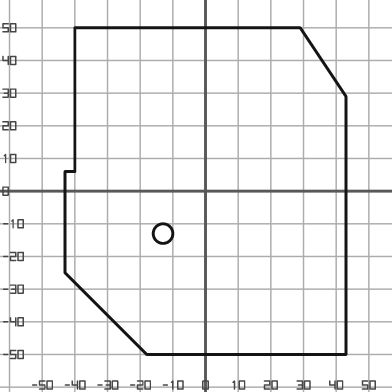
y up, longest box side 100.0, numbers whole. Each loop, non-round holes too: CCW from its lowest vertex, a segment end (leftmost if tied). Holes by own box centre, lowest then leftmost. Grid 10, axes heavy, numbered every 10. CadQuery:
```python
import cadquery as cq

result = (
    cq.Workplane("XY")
    .moveTo(-18.0, -50.0)
    .lineTo(43.0, -50.0)
    .lineTo(43.0, 29.0)
    .lineTo(29.0, 50.0)
    .lineTo(-40.0, 50.0)
    .lineTo(-40.0, 6.0)
    .lineTo(-43.0, 6.0)
    .lineTo(-43.0, -25.0)
    .close()
    .moveTo(-13.0, -13.0)
    .circle(3.0)
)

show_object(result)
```